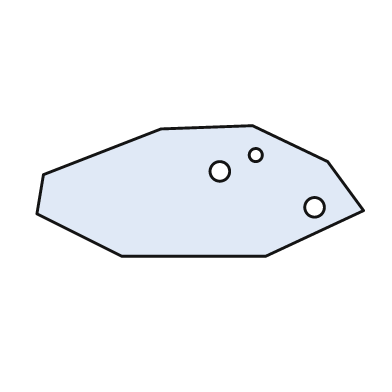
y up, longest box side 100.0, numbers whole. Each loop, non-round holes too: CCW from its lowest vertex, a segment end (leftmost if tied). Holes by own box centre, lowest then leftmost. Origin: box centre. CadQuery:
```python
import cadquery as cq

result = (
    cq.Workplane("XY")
    .moveTo(-24.0, -20.0)
    .lineTo(20.0, -20.0)
    .lineTo(50.0, -6.0)
    .lineTo(39.0, 9.0)
    .lineTo(16.0, 20.0)
    .lineTo(-12.0, 19.0)
    .lineTo(-48.0, 5.0)
    .lineTo(-50.0, -7.0)
    .close()
    .moveTo(35.0, -5.0)
    .circle(3.0)
    .moveTo(6.0, 6.0)
    .circle(3.0)
    .moveTo(17.0, 11.0)
    .circle(2.0)
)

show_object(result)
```